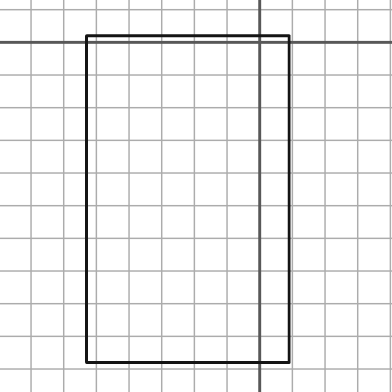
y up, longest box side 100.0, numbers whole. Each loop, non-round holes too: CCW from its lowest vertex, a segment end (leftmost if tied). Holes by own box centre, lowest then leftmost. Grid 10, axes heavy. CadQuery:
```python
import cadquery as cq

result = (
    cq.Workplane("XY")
    .moveTo(-53.0, -98.0)
    .lineTo(9.0, -98.0)
    .lineTo(9.0, 2.0)
    .lineTo(-53.0, 2.0)
    .close()
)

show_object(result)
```